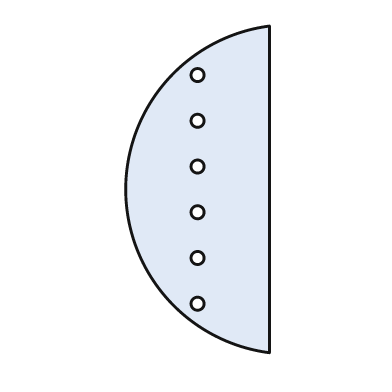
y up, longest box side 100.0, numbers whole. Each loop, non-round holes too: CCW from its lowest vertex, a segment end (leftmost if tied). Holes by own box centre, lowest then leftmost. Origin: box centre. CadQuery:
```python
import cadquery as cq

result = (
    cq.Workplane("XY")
    .moveTo(22.0, -50.0)
    .lineTo(22.0, 50.0)
    .threePointArc((-22.0, 0.0), (22.0, -50.0))
    .close()
    .moveTo(0.0, -35.0)
    .circle(2.0)
    .moveTo(0.0, -21.0)
    .circle(2.0)
    .moveTo(0.0, -7.0)
    .circle(2.0)
    .moveTo(0.0, 7.0)
    .circle(2.0)
    .moveTo(0.0, 21.0)
    .circle(2.0)
    .moveTo(0.0, 35.0)
    .circle(2.0)
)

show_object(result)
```